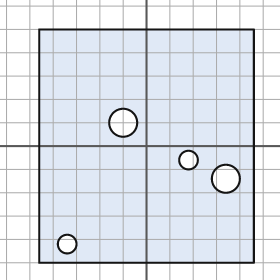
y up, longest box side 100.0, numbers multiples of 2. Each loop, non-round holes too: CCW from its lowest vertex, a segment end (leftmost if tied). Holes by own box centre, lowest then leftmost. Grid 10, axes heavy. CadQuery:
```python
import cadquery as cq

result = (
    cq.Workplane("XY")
    .moveTo(-46.0, -50.0)
    .lineTo(46.0, -50.0)
    .lineTo(46.0, 50.0)
    .lineTo(-46.0, 50.0)
    .close()
    .moveTo(-34.0, -42.0)
    .circle(4.0)
    .moveTo(34.0, -14.0)
    .circle(6.0)
    .moveTo(18.0, -6.0)
    .circle(4.0)
    .moveTo(-10.0, 10.0)
    .circle(6.0)
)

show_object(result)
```